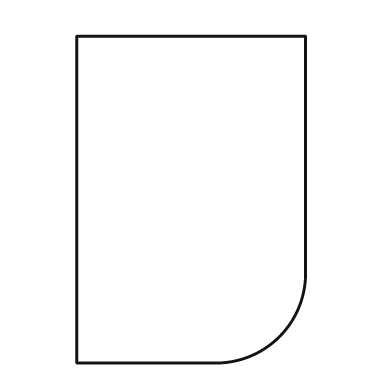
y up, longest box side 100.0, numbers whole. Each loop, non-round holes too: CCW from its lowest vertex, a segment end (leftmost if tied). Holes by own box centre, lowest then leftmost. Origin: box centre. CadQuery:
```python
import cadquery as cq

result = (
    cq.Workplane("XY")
    .moveTo(-35.0, -50.0)
    .lineTo(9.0, -50.0)
    .threePointArc((27.0, -42.0), (35.0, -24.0))
    .lineTo(35.0, 50.0)
    .lineTo(-35.0, 50.0)
    .close()
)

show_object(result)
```